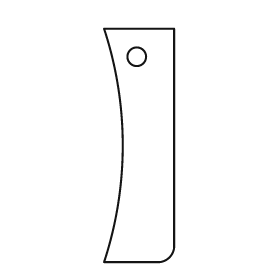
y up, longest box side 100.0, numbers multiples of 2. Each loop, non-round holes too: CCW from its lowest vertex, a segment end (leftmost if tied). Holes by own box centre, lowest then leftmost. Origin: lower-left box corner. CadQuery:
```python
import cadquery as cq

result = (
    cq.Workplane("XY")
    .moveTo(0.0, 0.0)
    .lineTo(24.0, 0.0)
    .threePointArc((28.0, 2.0), (30.0, 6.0))
    .lineTo(30.0, 100.0)
    .lineTo(0.0, 100.0)
    .threePointArc((8.0, 50.0), (0.0, 0.0))
    .close()
    .moveTo(14.0, 88.0)
    .circle(4.0)
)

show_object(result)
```